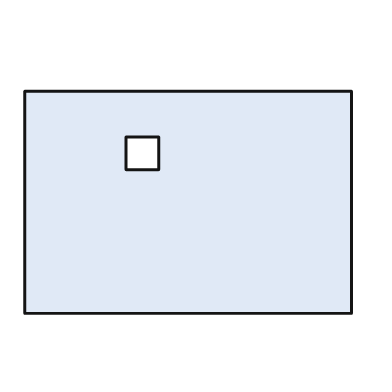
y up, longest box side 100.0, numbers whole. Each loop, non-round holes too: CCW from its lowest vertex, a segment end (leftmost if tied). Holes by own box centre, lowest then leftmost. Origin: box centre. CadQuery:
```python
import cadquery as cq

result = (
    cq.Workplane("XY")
    .moveTo(-50.0, -34.0)
    .lineTo(50.0, -34.0)
    .lineTo(50.0, 34.0)
    .lineTo(-50.0, 34.0)
    .close()
    .moveTo(-19.0, 10.0)
    .lineTo(-9.0, 10.0)
    .lineTo(-9.0, 20.0)
    .lineTo(-19.0, 20.0)
    .close()
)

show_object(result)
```